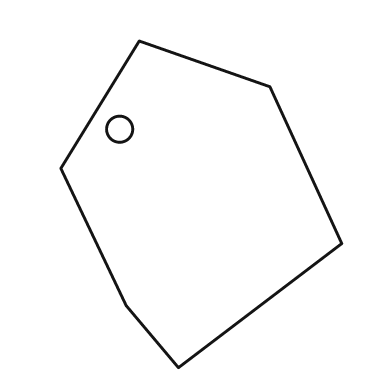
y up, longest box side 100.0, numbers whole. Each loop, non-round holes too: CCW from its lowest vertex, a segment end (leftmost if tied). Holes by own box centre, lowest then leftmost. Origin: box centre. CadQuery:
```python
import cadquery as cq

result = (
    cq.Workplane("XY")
    .moveTo(-7.0, -50.0)
    .lineTo(43.0, -12.0)
    .lineTo(21.0, 36.0)
    .lineTo(-19.0, 50.0)
    .lineTo(-43.0, 11.0)
    .lineTo(-23.0, -31.0)
    .close()
    .moveTo(-25.0, 23.0)
    .circle(4.0)
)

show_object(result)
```